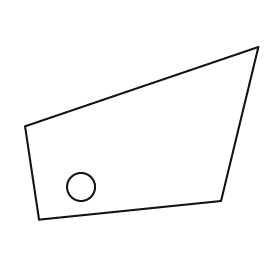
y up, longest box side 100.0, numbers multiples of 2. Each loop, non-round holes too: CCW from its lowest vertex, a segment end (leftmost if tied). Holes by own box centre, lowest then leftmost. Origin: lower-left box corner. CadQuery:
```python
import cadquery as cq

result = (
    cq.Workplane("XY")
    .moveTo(6.0, 0.0)
    .lineTo(84.0, 8.0)
    .lineTo(100.0, 74.0)
    .lineTo(0.0, 40.0)
    .close()
    .moveTo(24.0, 14.0)
    .circle(6.0)
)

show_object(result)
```